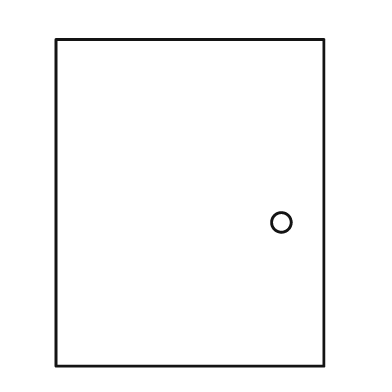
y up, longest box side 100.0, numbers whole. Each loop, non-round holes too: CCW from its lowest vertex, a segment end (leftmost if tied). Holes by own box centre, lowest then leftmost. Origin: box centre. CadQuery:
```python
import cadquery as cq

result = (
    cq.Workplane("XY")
    .moveTo(-41.0, -50.0)
    .lineTo(41.0, -50.0)
    .lineTo(41.0, 50.0)
    .lineTo(-41.0, 50.0)
    .close()
    .moveTo(28.0, -6.0)
    .circle(3.0)
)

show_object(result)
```